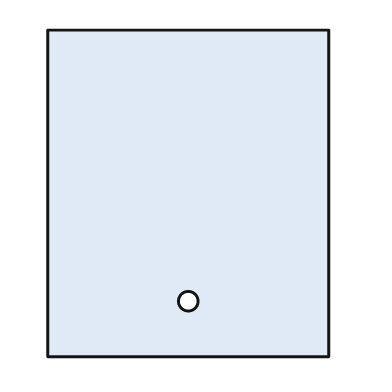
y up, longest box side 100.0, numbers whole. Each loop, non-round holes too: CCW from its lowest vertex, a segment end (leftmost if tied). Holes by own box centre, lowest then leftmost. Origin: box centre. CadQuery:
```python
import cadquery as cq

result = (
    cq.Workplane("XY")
    .moveTo(-43.0, -50.0)
    .lineTo(43.0, -50.0)
    .lineTo(43.0, 50.0)
    .lineTo(-43.0, 50.0)
    .close()
    .moveTo(0.0, -33.0)
    .circle(3.0)
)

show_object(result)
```